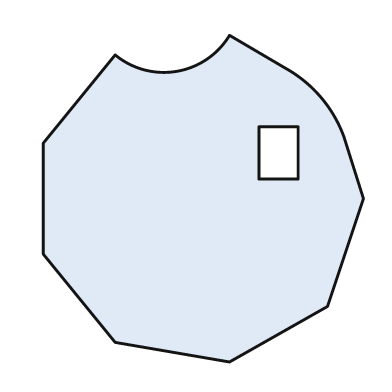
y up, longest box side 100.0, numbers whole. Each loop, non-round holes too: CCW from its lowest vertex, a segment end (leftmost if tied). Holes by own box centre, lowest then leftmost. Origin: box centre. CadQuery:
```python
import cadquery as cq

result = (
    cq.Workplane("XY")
    .moveTo(8.0, -50.0)
    .lineTo(38.0, -33.0)
    .lineTo(49.0, 0.0)
    .lineTo(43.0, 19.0)
    .threePointArc((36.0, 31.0), (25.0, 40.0))
    .lineTo(8.0, 50.0)
    .threePointArc((-8.0, 39.0), (-27.0, 44.0))
    .lineTo(-49.0, 17.0)
    .lineTo(-49.0, -17.0)
    .lineTo(-27.0, -44.0)
    .close()
    .moveTo(17.0, 6.0)
    .lineTo(29.0, 6.0)
    .lineTo(29.0, 22.0)
    .lineTo(17.0, 22.0)
    .close()
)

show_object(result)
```